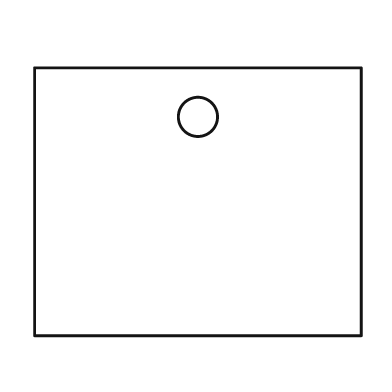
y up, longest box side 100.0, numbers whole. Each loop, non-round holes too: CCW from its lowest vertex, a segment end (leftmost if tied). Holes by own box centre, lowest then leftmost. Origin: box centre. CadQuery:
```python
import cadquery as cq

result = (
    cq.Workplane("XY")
    .moveTo(-50.0, -41.0)
    .lineTo(50.0, -41.0)
    .lineTo(50.0, 41.0)
    .lineTo(-50.0, 41.0)
    .close()
    .moveTo(0.0, 26.0)
    .circle(6.0)
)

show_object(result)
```